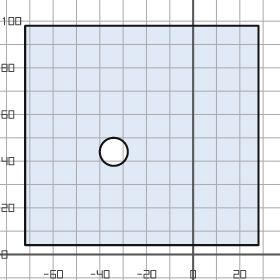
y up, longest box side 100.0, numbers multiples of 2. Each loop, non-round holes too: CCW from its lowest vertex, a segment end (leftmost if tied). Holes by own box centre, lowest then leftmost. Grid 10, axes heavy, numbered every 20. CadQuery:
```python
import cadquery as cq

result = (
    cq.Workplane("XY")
    .moveTo(-72.0, 4.0)
    .lineTo(28.0, 4.0)
    .lineTo(28.0, 98.0)
    .lineTo(-72.0, 98.0)
    .close()
    .moveTo(-34.0, 44.0)
    .circle(6.0)
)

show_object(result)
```